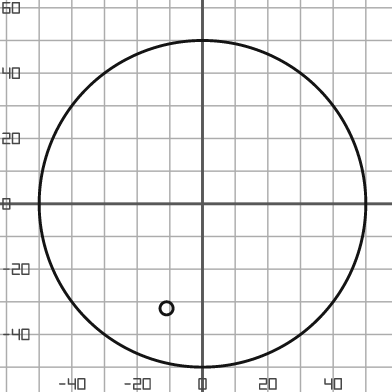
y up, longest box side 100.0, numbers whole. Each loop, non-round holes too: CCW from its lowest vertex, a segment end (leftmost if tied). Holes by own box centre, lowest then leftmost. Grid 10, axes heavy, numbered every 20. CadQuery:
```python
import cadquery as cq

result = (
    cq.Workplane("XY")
    .moveTo(0.0, 0.0)
    .circle(50.0)
    .moveTo(-11.0, -32.0)
    .circle(2.0)
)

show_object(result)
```